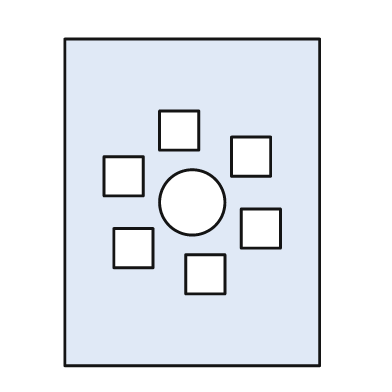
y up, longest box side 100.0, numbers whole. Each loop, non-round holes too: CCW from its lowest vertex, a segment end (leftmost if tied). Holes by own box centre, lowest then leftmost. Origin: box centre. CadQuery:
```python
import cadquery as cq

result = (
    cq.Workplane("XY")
    .moveTo(-39.0, -50.0)
    .lineTo(39.0, -50.0)
    .lineTo(39.0, 50.0)
    .lineTo(-39.0, 50.0)
    .close()
    .moveTo(-2.0, -28.0)
    .lineTo(10.0, -28.0)
    .lineTo(10.0, -16.0)
    .lineTo(-2.0, -16.0)
    .close()
    .moveTo(-24.0, -20.0)
    .lineTo(-12.0, -20.0)
    .lineTo(-12.0, -8.0)
    .lineTo(-24.0, -8.0)
    .close()
    .moveTo(15.0, -14.0)
    .lineTo(27.0, -14.0)
    .lineTo(27.0, -2.0)
    .lineTo(15.0, -2.0)
    .close()
    .moveTo(0.0, 0.0)
    .circle(10.0)
    .moveTo(-27.0, 2.0)
    .lineTo(-15.0, 2.0)
    .lineTo(-15.0, 14.0)
    .lineTo(-27.0, 14.0)
    .close()
    .moveTo(12.0, 8.0)
    .lineTo(24.0, 8.0)
    .lineTo(24.0, 20.0)
    .lineTo(12.0, 20.0)
    .close()
    .moveTo(-10.0, 16.0)
    .lineTo(2.0, 16.0)
    .lineTo(2.0, 28.0)
    .lineTo(-10.0, 28.0)
    .close()
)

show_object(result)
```